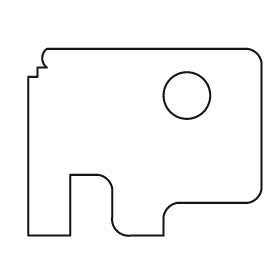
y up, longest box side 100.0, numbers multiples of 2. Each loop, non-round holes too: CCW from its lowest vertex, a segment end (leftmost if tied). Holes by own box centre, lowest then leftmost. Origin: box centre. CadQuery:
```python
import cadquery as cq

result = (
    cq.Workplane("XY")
    .moveTo(-50.0, -40.0)
    .lineTo(-32.0, -40.0)
    .lineTo(-32.0, -14.0)
    .lineTo(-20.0, -14.0)
    .threePointArc((-16.0, -16.0), (-14.0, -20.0))
    .lineTo(-14.0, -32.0)
    .threePointArc((-12.0, -38.0), (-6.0, -40.0))
    .lineTo(8.0, -40.0)
    .lineTo(8.0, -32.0)
    .threePointArc((10.0, -28.0), (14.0, -26.0))
    .lineTo(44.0, -26.0)
    .threePointArc((48.0, -24.0), (50.0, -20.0))
    .lineTo(50.0, 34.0)
    .threePointArc((48.0, 38.0), (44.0, 40.0))
    .lineTo(-42.0, 40.0)
    .threePointArc((-44.0, 36.0), (-42.0, 32.0))
    .lineTo(-46.0, 32.0)
    .lineTo(-46.0, 28.0)
    .lineTo(-50.0, 28.0)
    .close()
    .moveTo(18.0, 20.0)
    .circle(10.0)
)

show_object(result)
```